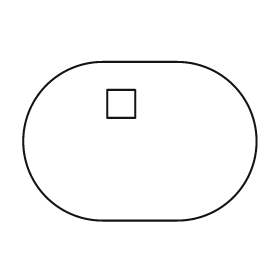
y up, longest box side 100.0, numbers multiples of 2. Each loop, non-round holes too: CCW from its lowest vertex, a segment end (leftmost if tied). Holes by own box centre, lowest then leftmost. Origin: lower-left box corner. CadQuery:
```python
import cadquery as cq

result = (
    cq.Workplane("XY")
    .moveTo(34.0, 0.0)
    .lineTo(66.0, 0.0)
    .threePointArc((100.0, 34.0), (66.0, 68.0))
    .lineTo(34.0, 68.0)
    .threePointArc((0.0, 34.0), (34.0, 0.0))
    .close()
    .moveTo(36.0, 44.0)
    .lineTo(48.0, 44.0)
    .lineTo(48.0, 56.0)
    .lineTo(36.0, 56.0)
    .close()
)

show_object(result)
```